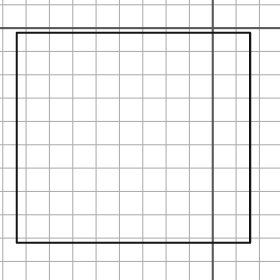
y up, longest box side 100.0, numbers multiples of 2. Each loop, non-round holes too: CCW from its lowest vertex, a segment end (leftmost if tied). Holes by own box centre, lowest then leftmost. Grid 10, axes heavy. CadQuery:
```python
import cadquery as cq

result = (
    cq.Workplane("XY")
    .moveTo(-84.0, -92.0)
    .lineTo(16.0, -92.0)
    .lineTo(16.0, -2.0)
    .lineTo(-84.0, -2.0)
    .close()
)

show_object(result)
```